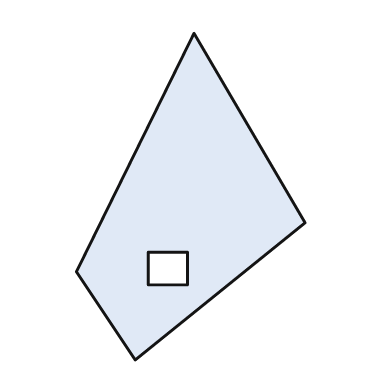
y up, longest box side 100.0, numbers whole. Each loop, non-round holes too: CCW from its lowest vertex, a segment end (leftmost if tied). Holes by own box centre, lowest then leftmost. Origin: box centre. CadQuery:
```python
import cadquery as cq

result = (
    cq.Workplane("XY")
    .moveTo(-17.0, -50.0)
    .lineTo(35.0, -8.0)
    .lineTo(1.0, 50.0)
    .lineTo(-35.0, -23.0)
    .close()
    .moveTo(-13.0, -27.0)
    .lineTo(-1.0, -27.0)
    .lineTo(-1.0, -17.0)
    .lineTo(-13.0, -17.0)
    .close()
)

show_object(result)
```